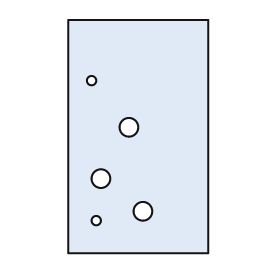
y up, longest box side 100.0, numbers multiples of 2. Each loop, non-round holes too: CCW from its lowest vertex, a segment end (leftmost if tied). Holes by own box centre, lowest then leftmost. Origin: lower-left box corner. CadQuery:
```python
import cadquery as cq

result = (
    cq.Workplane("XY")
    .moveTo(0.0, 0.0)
    .lineTo(60.0, 0.0)
    .lineTo(60.0, 100.0)
    .lineTo(0.0, 100.0)
    .close()
    .moveTo(12.0, 14.0)
    .circle(2.0)
    .moveTo(32.0, 18.0)
    .circle(4.0)
    .moveTo(14.0, 32.0)
    .circle(4.0)
    .moveTo(26.0, 54.0)
    .circle(4.0)
    .moveTo(10.0, 74.0)
    .circle(2.0)
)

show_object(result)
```